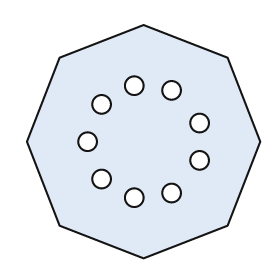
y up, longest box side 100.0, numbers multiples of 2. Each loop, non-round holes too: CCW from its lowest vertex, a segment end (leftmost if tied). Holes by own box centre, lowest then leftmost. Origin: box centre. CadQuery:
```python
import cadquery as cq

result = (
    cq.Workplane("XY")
    .moveTo(0.0, -50.0)
    .lineTo(36.0, -36.0)
    .lineTo(50.0, 0.0)
    .lineTo(36.0, 36.0)
    .lineTo(0.0, 50.0)
    .lineTo(-36.0, 36.0)
    .lineTo(-50.0, 0.0)
    .lineTo(-36.0, -36.0)
    .close()
    .moveTo(-4.0, -24.0)
    .circle(4.0)
    .moveTo(12.0, -22.0)
    .circle(4.0)
    .moveTo(-18.0, -16.0)
    .circle(4.0)
    .moveTo(24.0, -8.0)
    .circle(4.0)
    .moveTo(-24.0, 0.0)
    .circle(4.0)
    .moveTo(24.0, 8.0)
    .circle(4.0)
    .moveTo(-18.0, 16.0)
    .circle(4.0)
    .moveTo(12.0, 22.0)
    .circle(4.0)
    .moveTo(-4.0, 24.0)
    .circle(4.0)
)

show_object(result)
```